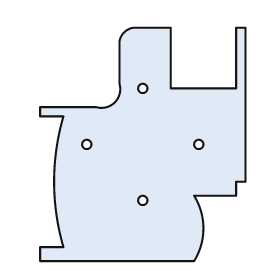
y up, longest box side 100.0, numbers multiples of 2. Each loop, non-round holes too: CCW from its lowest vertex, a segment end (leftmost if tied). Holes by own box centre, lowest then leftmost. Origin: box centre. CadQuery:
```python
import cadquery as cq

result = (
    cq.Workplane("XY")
    .moveTo(-44.0, -50.0)
    .lineTo(22.0, -50.0)
    .threePointArc((26.0, -36.0), (22.0, -22.0))
    .lineTo(40.0, -22.0)
    .lineTo(40.0, -16.0)
    .lineTo(44.0, -16.0)
    .lineTo(44.0, 50.0)
    .lineTo(40.0, 50.0)
    .lineTo(40.0, 24.0)
    .lineTo(12.0, 24.0)
    .lineTo(12.0, 50.0)
    .lineTo(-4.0, 50.0)
    .threePointArc((-8.0, 48.0), (-10.0, 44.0))
    .lineTo(-10.0, 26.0)
    .threePointArc((-12.0, 18.0), (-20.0, 16.0))
    .lineTo(-44.0, 16.0)
    .lineTo(-44.0, 12.0)
    .lineTo(-34.0, 12.0)
    .threePointArc((-38.0, -16.0), (-34.0, -44.0))
    .lineTo(-44.0, -44.0)
    .close()
    .moveTo(0.0, -24.0)
    .circle(2.0)
    .moveTo(-24.0, 0.0)
    .circle(2.0)
    .moveTo(24.0, 0.0)
    .circle(2.0)
    .moveTo(0.0, 24.0)
    .circle(2.0)
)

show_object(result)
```